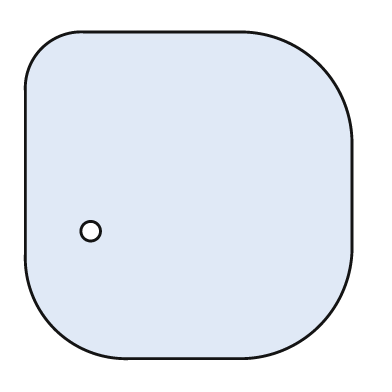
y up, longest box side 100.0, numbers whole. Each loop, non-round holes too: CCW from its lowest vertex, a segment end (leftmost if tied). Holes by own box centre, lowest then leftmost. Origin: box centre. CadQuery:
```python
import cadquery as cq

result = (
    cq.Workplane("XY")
    .moveTo(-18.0, -50.0)
    .lineTo(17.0, -50.0)
    .threePointArc((40.0, -40.0), (50.0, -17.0))
    .lineTo(50.0, 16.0)
    .threePointArc((40.0, 40.0), (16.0, 50.0))
    .lineTo(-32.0, 50.0)
    .threePointArc((-45.0, 45.0), (-50.0, 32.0))
    .lineTo(-50.0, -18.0)
    .threePointArc((-41.0, -41.0), (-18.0, -50.0))
    .close()
    .moveTo(-30.0, -11.0)
    .circle(3.0)
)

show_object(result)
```